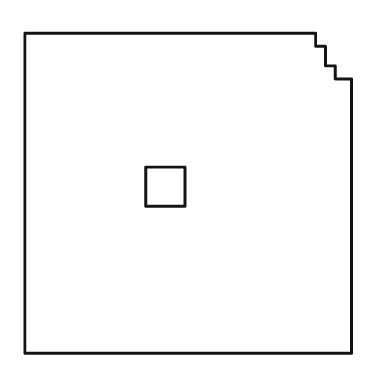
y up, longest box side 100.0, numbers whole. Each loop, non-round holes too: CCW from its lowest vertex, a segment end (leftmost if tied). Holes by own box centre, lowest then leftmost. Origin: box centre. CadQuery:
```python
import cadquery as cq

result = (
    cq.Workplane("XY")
    .moveTo(-50.0, -49.0)
    .lineTo(50.0, -49.0)
    .lineTo(50.0, 35.0)
    .lineTo(45.0, 35.0)
    .lineTo(45.0, 39.0)
    .lineTo(42.0, 39.0)
    .lineTo(42.0, 45.0)
    .lineTo(39.0, 45.0)
    .lineTo(39.0, 49.0)
    .lineTo(-50.0, 49.0)
    .close()
    .moveTo(-13.0, -4.0)
    .lineTo(-1.0, -4.0)
    .lineTo(-1.0, 8.0)
    .lineTo(-13.0, 8.0)
    .close()
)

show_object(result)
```